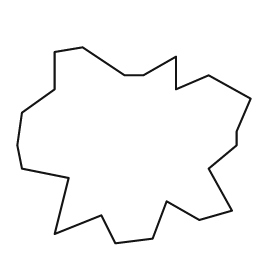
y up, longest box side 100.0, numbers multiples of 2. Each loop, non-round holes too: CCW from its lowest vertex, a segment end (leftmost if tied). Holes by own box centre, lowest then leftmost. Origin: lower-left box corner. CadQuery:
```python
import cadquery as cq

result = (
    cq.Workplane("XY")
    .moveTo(42.0, 0.0)
    .lineTo(58.0, 2.0)
    .lineTo(64.0, 18.0)
    .lineTo(78.0, 10.0)
    .lineTo(92.0, 14.0)
    .lineTo(82.0, 32.0)
    .lineTo(94.0, 42.0)
    .lineTo(94.0, 48.0)
    .lineTo(100.0, 62.0)
    .lineTo(82.0, 72.0)
    .lineTo(68.0, 66.0)
    .lineTo(68.0, 80.0)
    .lineTo(54.0, 72.0)
    .lineTo(46.0, 72.0)
    .lineTo(28.0, 84.0)
    .lineTo(16.0, 82.0)
    .lineTo(16.0, 66.0)
    .lineTo(2.0, 56.0)
    .lineTo(0.0, 42.0)
    .lineTo(2.0, 32.0)
    .lineTo(22.0, 28.0)
    .lineTo(16.0, 4.0)
    .lineTo(36.0, 12.0)
    .close()
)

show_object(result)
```